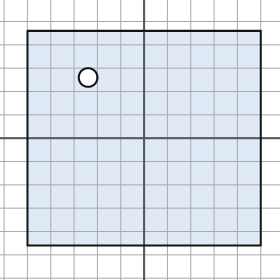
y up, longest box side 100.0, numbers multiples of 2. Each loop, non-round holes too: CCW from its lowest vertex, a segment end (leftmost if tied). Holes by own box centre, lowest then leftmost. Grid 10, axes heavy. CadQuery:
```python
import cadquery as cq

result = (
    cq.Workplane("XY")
    .moveTo(-50.0, -46.0)
    .lineTo(50.0, -46.0)
    .lineTo(50.0, 46.0)
    .lineTo(-50.0, 46.0)
    .close()
    .moveTo(-24.0, 26.0)
    .circle(4.0)
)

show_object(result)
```